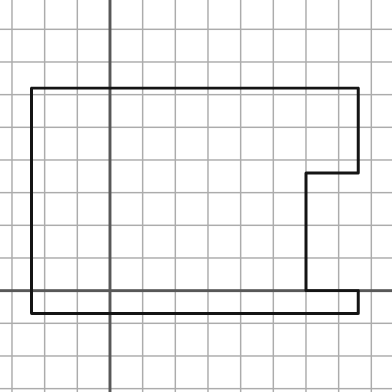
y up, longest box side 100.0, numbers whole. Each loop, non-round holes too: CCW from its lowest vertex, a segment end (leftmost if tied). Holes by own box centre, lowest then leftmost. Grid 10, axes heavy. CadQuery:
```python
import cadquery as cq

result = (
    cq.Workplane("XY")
    .moveTo(-24.0, -7.0)
    .lineTo(76.0, -7.0)
    .lineTo(76.0, 0.0)
    .lineTo(60.0, 0.0)
    .lineTo(60.0, 36.0)
    .lineTo(76.0, 36.0)
    .lineTo(76.0, 62.0)
    .lineTo(-24.0, 62.0)
    .close()
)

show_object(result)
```